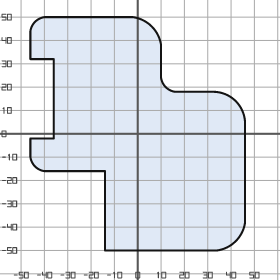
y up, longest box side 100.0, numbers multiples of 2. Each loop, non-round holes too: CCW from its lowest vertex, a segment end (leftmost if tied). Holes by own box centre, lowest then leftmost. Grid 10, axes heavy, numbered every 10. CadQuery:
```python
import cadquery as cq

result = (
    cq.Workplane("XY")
    .moveTo(-14.0, -50.0)
    .lineTo(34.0, -50.0)
    .threePointArc((42.0, -46.0), (46.0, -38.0))
    .lineTo(46.0, 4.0)
    .threePointArc((42.0, 14.0), (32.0, 18.0))
    .lineTo(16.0, 18.0)
    .threePointArc((12.0, 20.0), (10.0, 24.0))
    .lineTo(10.0, 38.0)
    .threePointArc((6.0, 46.0), (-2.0, 50.0))
    .lineTo(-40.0, 50.0)
    .threePointArc((-44.0, 48.0), (-46.0, 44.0))
    .lineTo(-46.0, 32.0)
    .lineTo(-36.0, 32.0)
    .lineTo(-36.0, -2.0)
    .lineTo(-46.0, -2.0)
    .lineTo(-46.0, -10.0)
    .threePointArc((-44.0, -14.0), (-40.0, -16.0))
    .lineTo(-14.0, -16.0)
    .close()
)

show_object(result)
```